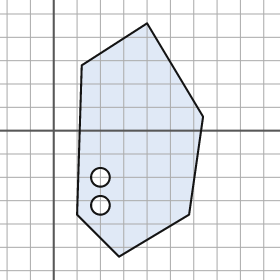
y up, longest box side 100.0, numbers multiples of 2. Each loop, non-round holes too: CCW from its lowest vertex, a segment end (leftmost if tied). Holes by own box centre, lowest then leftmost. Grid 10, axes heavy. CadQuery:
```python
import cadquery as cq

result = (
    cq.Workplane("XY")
    .moveTo(28.0, -54.0)
    .lineTo(58.0, -36.0)
    .lineTo(64.0, 6.0)
    .lineTo(40.0, 46.0)
    .lineTo(12.0, 28.0)
    .lineTo(10.0, -36.0)
    .close()
    .moveTo(20.0, -32.0)
    .circle(4.0)
    .moveTo(20.0, -20.0)
    .circle(4.0)
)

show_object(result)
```